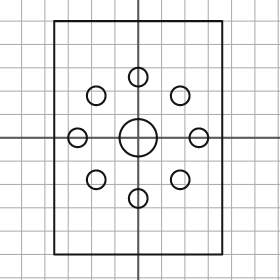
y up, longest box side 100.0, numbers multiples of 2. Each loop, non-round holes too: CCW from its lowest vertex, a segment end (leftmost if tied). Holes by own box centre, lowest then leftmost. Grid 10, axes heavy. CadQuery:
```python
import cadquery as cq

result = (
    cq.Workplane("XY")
    .moveTo(-36.0, -50.0)
    .lineTo(36.0, -50.0)
    .lineTo(36.0, 50.0)
    .lineTo(-36.0, 50.0)
    .close()
    .moveTo(0.0, -26.0)
    .circle(4.0)
    .moveTo(-18.0, -18.0)
    .circle(4.0)
    .moveTo(18.0, -18.0)
    .circle(4.0)
    .moveTo(-26.0, 0.0)
    .circle(4.0)
    .moveTo(0.0, 0.0)
    .circle(8.0)
    .moveTo(26.0, 0.0)
    .circle(4.0)
    .moveTo(-18.0, 18.0)
    .circle(4.0)
    .moveTo(18.0, 18.0)
    .circle(4.0)
    .moveTo(0.0, 26.0)
    .circle(4.0)
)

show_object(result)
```